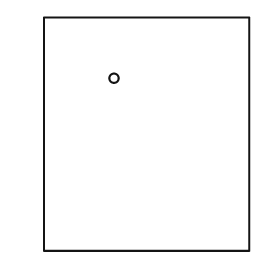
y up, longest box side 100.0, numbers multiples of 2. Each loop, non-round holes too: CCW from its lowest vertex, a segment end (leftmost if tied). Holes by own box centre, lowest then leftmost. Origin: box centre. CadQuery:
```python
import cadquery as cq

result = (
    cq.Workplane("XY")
    .moveTo(-44.0, -50.0)
    .lineTo(44.0, -50.0)
    .lineTo(44.0, 50.0)
    .lineTo(-44.0, 50.0)
    .close()
    .moveTo(-14.0, 24.0)
    .circle(2.0)
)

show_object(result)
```